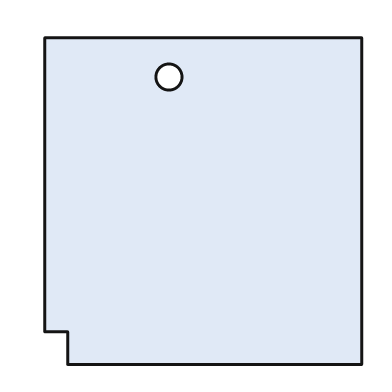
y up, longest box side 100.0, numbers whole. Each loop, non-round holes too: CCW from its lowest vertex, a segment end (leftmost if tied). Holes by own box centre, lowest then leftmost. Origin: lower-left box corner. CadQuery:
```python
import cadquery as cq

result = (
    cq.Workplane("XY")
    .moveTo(7.0, 0.0)
    .lineTo(97.0, 0.0)
    .lineTo(97.0, 100.0)
    .lineTo(0.0, 100.0)
    .lineTo(0.0, 10.0)
    .lineTo(7.0, 10.0)
    .close()
    .moveTo(38.0, 88.0)
    .circle(4.0)
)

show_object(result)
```